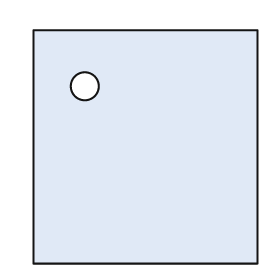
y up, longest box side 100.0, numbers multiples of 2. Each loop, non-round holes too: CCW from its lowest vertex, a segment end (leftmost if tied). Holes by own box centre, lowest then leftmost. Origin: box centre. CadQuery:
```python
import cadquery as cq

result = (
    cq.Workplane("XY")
    .moveTo(-48.0, -50.0)
    .lineTo(48.0, -50.0)
    .lineTo(48.0, 50.0)
    .lineTo(-48.0, 50.0)
    .close()
    .moveTo(-26.0, 26.0)
    .circle(6.0)
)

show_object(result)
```